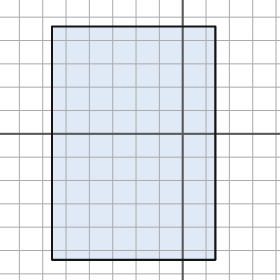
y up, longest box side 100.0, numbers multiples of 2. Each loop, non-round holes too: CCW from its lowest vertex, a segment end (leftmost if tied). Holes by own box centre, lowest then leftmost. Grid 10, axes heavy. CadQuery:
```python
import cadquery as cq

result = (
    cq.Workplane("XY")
    .moveTo(-56.0, -54.0)
    .lineTo(14.0, -54.0)
    .lineTo(14.0, 46.0)
    .lineTo(-56.0, 46.0)
    .close()
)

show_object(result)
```